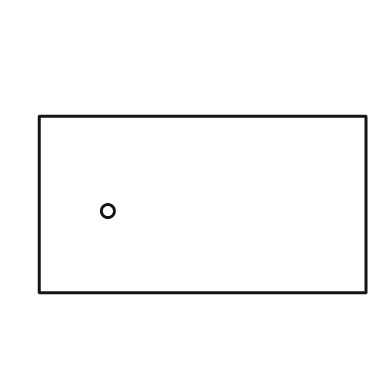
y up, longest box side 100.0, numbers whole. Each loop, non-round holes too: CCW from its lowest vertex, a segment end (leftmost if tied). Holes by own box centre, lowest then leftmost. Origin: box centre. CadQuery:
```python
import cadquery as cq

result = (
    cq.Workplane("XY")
    .moveTo(-50.0, -27.0)
    .lineTo(50.0, -27.0)
    .lineTo(50.0, 27.0)
    .lineTo(-50.0, 27.0)
    .close()
    .moveTo(-29.0, -2.0)
    .circle(2.0)
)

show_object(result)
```